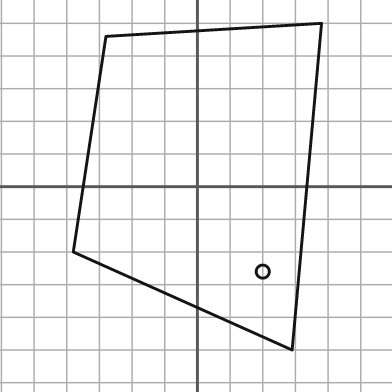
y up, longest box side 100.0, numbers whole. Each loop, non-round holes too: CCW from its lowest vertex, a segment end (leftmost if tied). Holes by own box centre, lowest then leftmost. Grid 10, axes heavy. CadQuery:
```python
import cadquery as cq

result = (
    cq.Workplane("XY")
    .moveTo(29.0, -50.0)
    .lineTo(38.0, 50.0)
    .lineTo(-28.0, 46.0)
    .lineTo(-38.0, -20.0)
    .close()
    .moveTo(20.0, -26.0)
    .circle(2.0)
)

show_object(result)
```